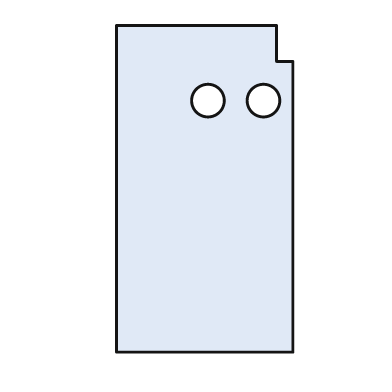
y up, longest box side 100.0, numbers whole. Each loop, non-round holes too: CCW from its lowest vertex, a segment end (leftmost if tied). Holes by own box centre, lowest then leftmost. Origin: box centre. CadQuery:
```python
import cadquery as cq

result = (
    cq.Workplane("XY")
    .moveTo(-27.0, -50.0)
    .lineTo(27.0, -50.0)
    .lineTo(27.0, 39.0)
    .lineTo(22.0, 39.0)
    .lineTo(22.0, 50.0)
    .lineTo(-27.0, 50.0)
    .close()
    .moveTo(1.0, 27.0)
    .circle(5.0)
    .moveTo(18.0, 27.0)
    .circle(5.0)
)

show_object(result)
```